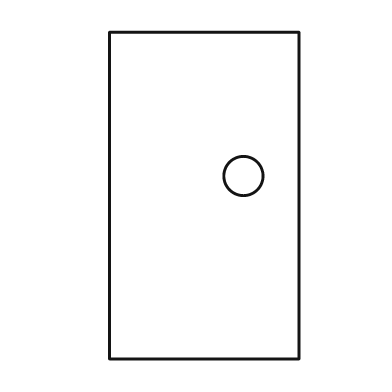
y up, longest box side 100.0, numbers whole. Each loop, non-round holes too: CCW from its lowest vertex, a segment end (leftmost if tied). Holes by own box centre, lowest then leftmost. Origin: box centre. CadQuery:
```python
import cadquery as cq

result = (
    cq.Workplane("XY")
    .moveTo(-29.0, -50.0)
    .lineTo(29.0, -50.0)
    .lineTo(29.0, 50.0)
    .lineTo(-29.0, 50.0)
    .close()
    .moveTo(12.0, 6.0)
    .circle(6.0)
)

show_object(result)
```